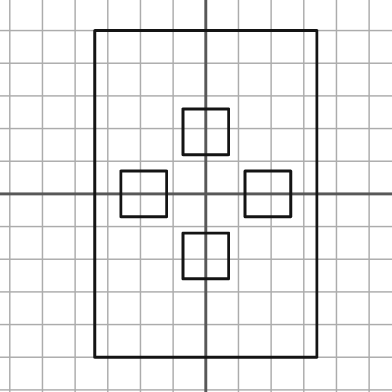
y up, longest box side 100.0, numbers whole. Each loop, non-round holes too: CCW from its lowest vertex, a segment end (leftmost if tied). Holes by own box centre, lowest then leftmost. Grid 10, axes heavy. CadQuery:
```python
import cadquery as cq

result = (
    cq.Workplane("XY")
    .moveTo(-34.0, -50.0)
    .lineTo(34.0, -50.0)
    .lineTo(34.0, 50.0)
    .lineTo(-34.0, 50.0)
    .close()
    .moveTo(-7.0, -26.0)
    .lineTo(7.0, -26.0)
    .lineTo(7.0, -12.0)
    .lineTo(-7.0, -12.0)
    .close()
    .moveTo(-26.0, -7.0)
    .lineTo(-12.0, -7.0)
    .lineTo(-12.0, 7.0)
    .lineTo(-26.0, 7.0)
    .close()
    .moveTo(12.0, -7.0)
    .lineTo(26.0, -7.0)
    .lineTo(26.0, 7.0)
    .lineTo(12.0, 7.0)
    .close()
    .moveTo(-7.0, 12.0)
    .lineTo(7.0, 12.0)
    .lineTo(7.0, 26.0)
    .lineTo(-7.0, 26.0)
    .close()
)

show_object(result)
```